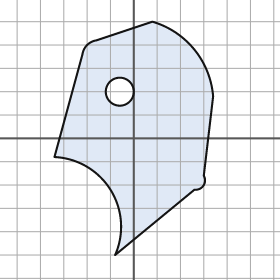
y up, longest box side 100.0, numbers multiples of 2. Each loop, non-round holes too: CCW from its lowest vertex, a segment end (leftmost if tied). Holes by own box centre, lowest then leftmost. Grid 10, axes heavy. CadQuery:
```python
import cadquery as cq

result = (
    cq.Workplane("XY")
    .moveTo(-8.0, -50.0)
    .lineTo(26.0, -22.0)
    .threePointArc((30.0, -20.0), (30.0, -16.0))
    .lineTo(34.0, 18.0)
    .threePointArc((26.0, 38.0), (8.0, 50.0))
    .lineTo(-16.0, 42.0)
    .threePointArc((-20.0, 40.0), (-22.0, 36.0))
    .lineTo(-34.0, -8.0)
    .threePointArc((-10.0, -22.0), (-8.0, -50.0))
    .close()
    .moveTo(-6.0, 20.0)
    .circle(6.0)
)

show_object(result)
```